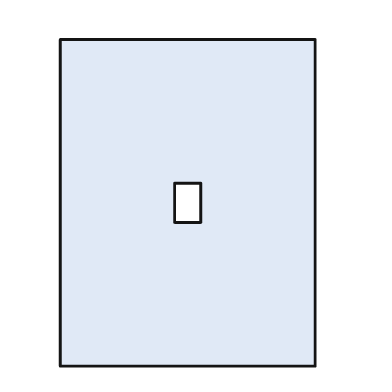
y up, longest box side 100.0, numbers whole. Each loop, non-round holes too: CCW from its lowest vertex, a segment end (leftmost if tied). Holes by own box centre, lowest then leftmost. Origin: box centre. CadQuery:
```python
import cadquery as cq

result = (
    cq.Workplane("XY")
    .moveTo(-39.0, -50.0)
    .lineTo(39.0, -50.0)
    .lineTo(39.0, 50.0)
    .lineTo(-39.0, 50.0)
    .close()
    .moveTo(-4.0, -6.0)
    .lineTo(4.0, -6.0)
    .lineTo(4.0, 6.0)
    .lineTo(-4.0, 6.0)
    .close()
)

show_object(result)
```